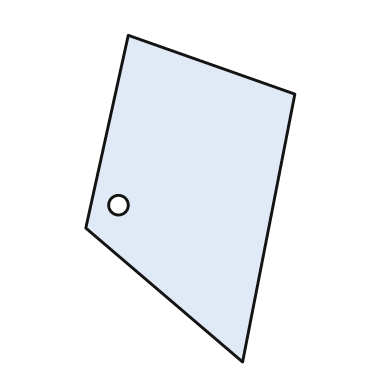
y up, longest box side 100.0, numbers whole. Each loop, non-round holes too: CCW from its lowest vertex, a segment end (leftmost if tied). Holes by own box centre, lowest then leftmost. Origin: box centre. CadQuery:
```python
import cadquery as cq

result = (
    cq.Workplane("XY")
    .moveTo(16.0, -50.0)
    .lineTo(32.0, 32.0)
    .lineTo(-19.0, 50.0)
    .lineTo(-32.0, -9.0)
    .close()
    .moveTo(-22.0, -2.0)
    .circle(3.0)
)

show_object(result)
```